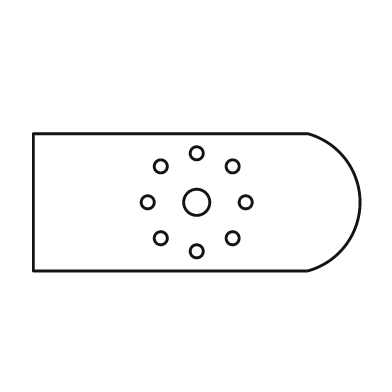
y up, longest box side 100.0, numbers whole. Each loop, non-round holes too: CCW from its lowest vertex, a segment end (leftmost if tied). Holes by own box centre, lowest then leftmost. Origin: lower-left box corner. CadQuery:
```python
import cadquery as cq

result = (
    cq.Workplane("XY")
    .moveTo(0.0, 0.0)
    .lineTo(84.0, 0.0)
    .threePointArc((100.0, 21.0), (84.0, 42.0))
    .lineTo(0.0, 42.0)
    .close()
    .moveTo(50.0, 6.0)
    .circle(2.0)
    .moveTo(39.0, 10.0)
    .circle(2.0)
    .moveTo(61.0, 10.0)
    .circle(2.0)
    .moveTo(35.0, 21.0)
    .circle(2.0)
    .moveTo(50.0, 21.0)
    .circle(4.0)
    .moveTo(65.0, 21.0)
    .circle(2.0)
    .moveTo(39.0, 32.0)
    .circle(2.0)
    .moveTo(61.0, 32.0)
    .circle(2.0)
    .moveTo(50.0, 36.0)
    .circle(2.0)
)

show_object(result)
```